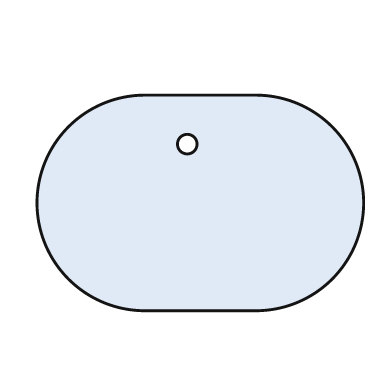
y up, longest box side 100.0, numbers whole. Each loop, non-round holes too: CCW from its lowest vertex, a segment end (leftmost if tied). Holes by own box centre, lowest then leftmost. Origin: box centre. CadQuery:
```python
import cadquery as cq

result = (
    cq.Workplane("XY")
    .moveTo(-17.0, -33.0)
    .lineTo(17.0, -33.0)
    .threePointArc((50.0, 0.0), (17.0, 33.0))
    .lineTo(-17.0, 33.0)
    .threePointArc((-50.0, 0.0), (-17.0, -33.0))
    .close()
    .moveTo(-4.0, 18.0)
    .circle(3.0)
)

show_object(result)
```